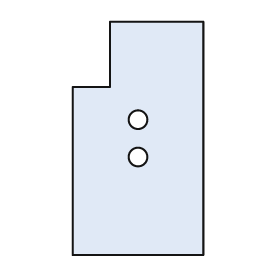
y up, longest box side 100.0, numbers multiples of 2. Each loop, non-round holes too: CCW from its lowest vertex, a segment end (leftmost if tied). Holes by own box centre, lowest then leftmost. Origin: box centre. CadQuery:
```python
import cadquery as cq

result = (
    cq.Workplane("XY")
    .moveTo(-28.0, -50.0)
    .lineTo(28.0, -50.0)
    .lineTo(28.0, 50.0)
    .lineTo(-12.0, 50.0)
    .lineTo(-12.0, 22.0)
    .lineTo(-28.0, 22.0)
    .close()
    .moveTo(0.0, -8.0)
    .circle(4.0)
    .moveTo(0.0, 8.0)
    .circle(4.0)
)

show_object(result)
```